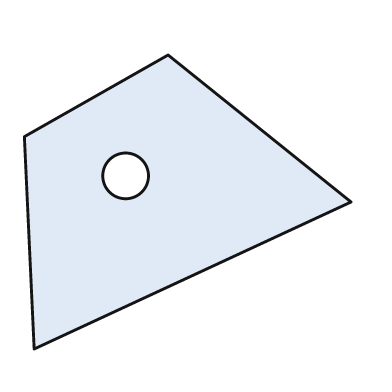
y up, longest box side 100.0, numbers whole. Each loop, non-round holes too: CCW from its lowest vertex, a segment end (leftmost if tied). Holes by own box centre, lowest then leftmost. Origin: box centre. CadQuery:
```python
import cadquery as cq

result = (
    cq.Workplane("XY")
    .moveTo(-47.0, -45.0)
    .lineTo(50.0, 0.0)
    .lineTo(-6.0, 45.0)
    .lineTo(-50.0, 20.0)
    .close()
    .moveTo(-19.0, 8.0)
    .circle(7.0)
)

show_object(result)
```